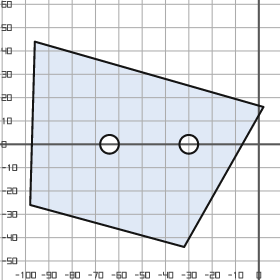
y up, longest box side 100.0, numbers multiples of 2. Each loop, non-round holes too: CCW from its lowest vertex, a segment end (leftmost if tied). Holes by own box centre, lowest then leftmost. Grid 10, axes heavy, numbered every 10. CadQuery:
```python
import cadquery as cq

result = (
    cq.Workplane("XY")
    .moveTo(-32.0, -44.0)
    .lineTo(2.0, 16.0)
    .lineTo(-96.0, 44.0)
    .lineTo(-98.0, -26.0)
    .close()
    .moveTo(-64.0, 0.0)
    .circle(4.0)
    .moveTo(-30.0, 0.0)
    .circle(4.0)
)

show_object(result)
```